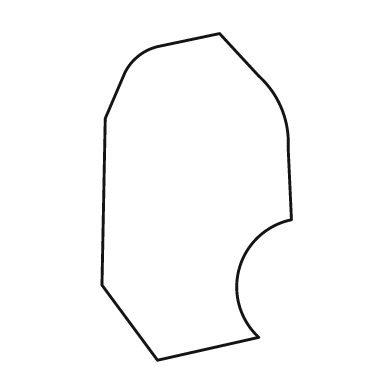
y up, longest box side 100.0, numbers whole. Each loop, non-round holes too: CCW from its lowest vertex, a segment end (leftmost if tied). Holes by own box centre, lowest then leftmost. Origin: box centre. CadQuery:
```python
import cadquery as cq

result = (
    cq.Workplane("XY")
    .moveTo(-12.0, -50.0)
    .lineTo(19.0, -43.0)
    .threePointArc((13.0, -22.0), (29.0, -7.0))
    .lineTo(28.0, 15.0)
    .threePointArc((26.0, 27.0), (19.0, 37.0))
    .lineTo(7.0, 50.0)
    .lineTo(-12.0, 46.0)
    .threePointArc((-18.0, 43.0), (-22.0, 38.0))
    .lineTo(-28.0, 24.0)
    .lineTo(-29.0, -27.0)
    .close()
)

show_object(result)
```